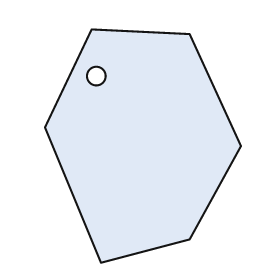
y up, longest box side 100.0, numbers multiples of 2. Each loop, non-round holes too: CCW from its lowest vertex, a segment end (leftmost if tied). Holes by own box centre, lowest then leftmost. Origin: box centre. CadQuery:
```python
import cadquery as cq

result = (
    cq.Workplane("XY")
    .moveTo(-18.0, -50.0)
    .lineTo(20.0, -40.0)
    .lineTo(42.0, 0.0)
    .lineTo(20.0, 48.0)
    .lineTo(-22.0, 50.0)
    .lineTo(-42.0, 8.0)
    .close()
    .moveTo(-20.0, 30.0)
    .circle(4.0)
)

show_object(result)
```